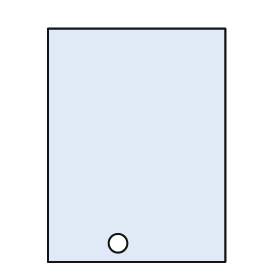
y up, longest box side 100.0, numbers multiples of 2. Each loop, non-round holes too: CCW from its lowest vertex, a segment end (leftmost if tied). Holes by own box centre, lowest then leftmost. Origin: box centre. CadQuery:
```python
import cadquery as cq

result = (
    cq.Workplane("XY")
    .moveTo(-38.0, -50.0)
    .lineTo(38.0, -50.0)
    .lineTo(38.0, 50.0)
    .lineTo(-38.0, 50.0)
    .close()
    .moveTo(-8.0, -42.0)
    .circle(4.0)
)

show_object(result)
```